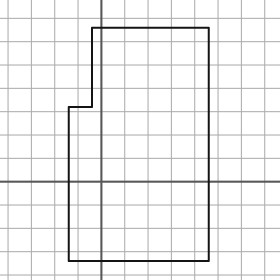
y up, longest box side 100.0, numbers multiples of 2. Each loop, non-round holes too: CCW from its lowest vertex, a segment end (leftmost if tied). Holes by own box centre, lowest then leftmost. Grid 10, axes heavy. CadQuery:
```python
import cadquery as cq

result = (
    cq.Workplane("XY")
    .moveTo(-14.0, -34.0)
    .lineTo(46.0, -34.0)
    .lineTo(46.0, 66.0)
    .lineTo(-4.0, 66.0)
    .lineTo(-4.0, 32.0)
    .lineTo(-14.0, 32.0)
    .close()
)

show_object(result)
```